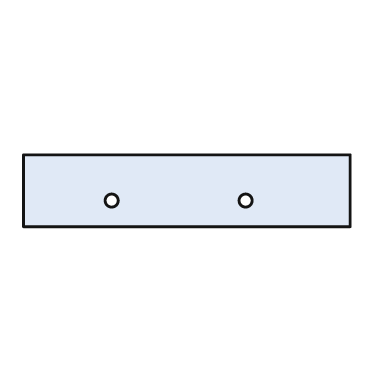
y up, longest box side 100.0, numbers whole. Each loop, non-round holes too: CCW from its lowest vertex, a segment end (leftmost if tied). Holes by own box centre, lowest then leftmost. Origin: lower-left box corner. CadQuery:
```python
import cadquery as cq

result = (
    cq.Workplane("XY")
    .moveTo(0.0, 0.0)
    .lineTo(100.0, 0.0)
    .lineTo(100.0, 22.0)
    .lineTo(0.0, 22.0)
    .close()
    .moveTo(27.0, 8.0)
    .circle(2.0)
    .moveTo(68.0, 8.0)
    .circle(2.0)
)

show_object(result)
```